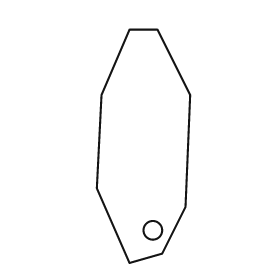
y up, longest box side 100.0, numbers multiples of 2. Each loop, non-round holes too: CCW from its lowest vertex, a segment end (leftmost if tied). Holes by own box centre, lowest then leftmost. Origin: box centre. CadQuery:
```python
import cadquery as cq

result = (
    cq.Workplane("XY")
    .moveTo(-6.0, -50.0)
    .lineTo(8.0, -46.0)
    .lineTo(18.0, -26.0)
    .lineTo(20.0, 22.0)
    .lineTo(6.0, 50.0)
    .lineTo(-6.0, 50.0)
    .lineTo(-18.0, 22.0)
    .lineTo(-20.0, -18.0)
    .close()
    .moveTo(4.0, -36.0)
    .circle(4.0)
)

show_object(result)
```